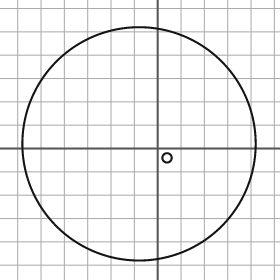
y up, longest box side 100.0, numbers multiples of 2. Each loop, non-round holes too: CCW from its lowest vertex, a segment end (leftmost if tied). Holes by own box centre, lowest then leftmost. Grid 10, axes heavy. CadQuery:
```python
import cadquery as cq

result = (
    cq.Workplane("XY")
    .moveTo(-8.0, 2.0)
    .circle(50.0)
    .moveTo(4.0, -4.0)
    .circle(2.0)
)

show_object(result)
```